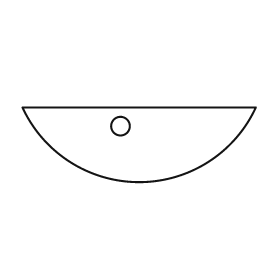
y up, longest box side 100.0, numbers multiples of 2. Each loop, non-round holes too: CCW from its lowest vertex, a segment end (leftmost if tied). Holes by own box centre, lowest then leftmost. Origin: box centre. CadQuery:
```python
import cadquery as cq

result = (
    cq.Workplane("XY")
    .moveTo(-50.0, 16.0)
    .threePointArc((0.0, -16.0), (50.0, 16.0))
    .close()
    .moveTo(-8.0, 8.0)
    .circle(4.0)
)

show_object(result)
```